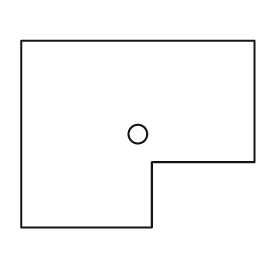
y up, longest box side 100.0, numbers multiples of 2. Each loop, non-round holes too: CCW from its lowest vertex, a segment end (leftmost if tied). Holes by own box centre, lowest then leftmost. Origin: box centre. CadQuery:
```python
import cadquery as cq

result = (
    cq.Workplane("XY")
    .moveTo(-50.0, -40.0)
    .lineTo(6.0, -40.0)
    .lineTo(6.0, -12.0)
    .lineTo(50.0, -12.0)
    .lineTo(50.0, 40.0)
    .lineTo(-50.0, 40.0)
    .close()
    .moveTo(0.0, 0.0)
    .circle(4.0)
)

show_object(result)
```